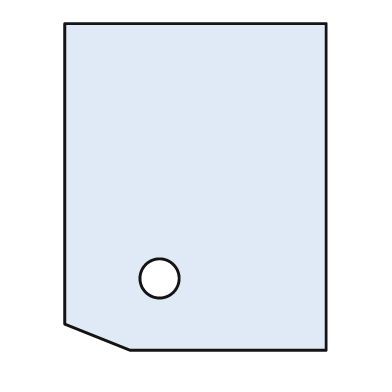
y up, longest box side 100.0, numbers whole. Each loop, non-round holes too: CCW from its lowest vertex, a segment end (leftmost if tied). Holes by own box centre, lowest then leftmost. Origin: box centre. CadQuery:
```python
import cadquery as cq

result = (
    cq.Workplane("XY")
    .moveTo(-20.0, -50.0)
    .lineTo(40.0, -50.0)
    .lineTo(40.0, 50.0)
    .lineTo(-40.0, 50.0)
    .lineTo(-40.0, -42.0)
    .close()
    .moveTo(-11.0, -28.0)
    .circle(6.0)
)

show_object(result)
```